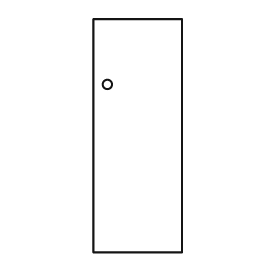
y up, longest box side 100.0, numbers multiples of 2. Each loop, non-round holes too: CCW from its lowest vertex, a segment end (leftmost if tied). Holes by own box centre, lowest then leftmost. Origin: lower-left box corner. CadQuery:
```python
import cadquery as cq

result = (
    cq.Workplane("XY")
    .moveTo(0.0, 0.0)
    .lineTo(38.0, 0.0)
    .lineTo(38.0, 100.0)
    .lineTo(0.0, 100.0)
    .close()
    .moveTo(6.0, 72.0)
    .circle(2.0)
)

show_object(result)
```